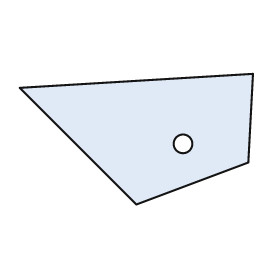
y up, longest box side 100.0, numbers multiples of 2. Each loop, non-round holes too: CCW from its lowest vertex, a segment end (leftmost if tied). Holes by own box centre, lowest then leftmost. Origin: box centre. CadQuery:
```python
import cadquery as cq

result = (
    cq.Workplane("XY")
    .moveTo(0.0, -28.0)
    .lineTo(48.0, -10.0)
    .lineTo(50.0, 28.0)
    .lineTo(-50.0, 22.0)
    .close()
    .moveTo(20.0, -2.0)
    .circle(4.0)
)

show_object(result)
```